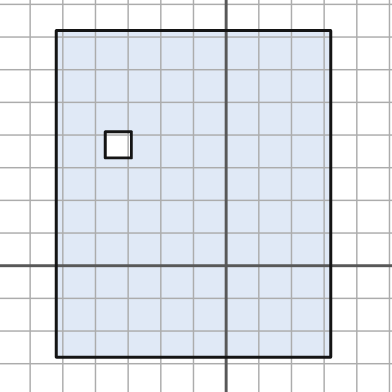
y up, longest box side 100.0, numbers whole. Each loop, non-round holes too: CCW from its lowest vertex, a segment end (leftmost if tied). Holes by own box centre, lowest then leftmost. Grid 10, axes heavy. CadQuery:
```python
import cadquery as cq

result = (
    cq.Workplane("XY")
    .moveTo(-52.0, -28.0)
    .lineTo(32.0, -28.0)
    .lineTo(32.0, 72.0)
    .lineTo(-52.0, 72.0)
    .close()
    .moveTo(-37.0, 33.0)
    .lineTo(-29.0, 33.0)
    .lineTo(-29.0, 41.0)
    .lineTo(-37.0, 41.0)
    .close()
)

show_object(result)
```